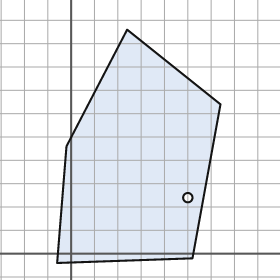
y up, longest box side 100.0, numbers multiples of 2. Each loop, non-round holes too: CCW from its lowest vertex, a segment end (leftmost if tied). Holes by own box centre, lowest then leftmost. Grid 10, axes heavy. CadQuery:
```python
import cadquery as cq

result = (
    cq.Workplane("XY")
    .moveTo(-6.0, -4.0)
    .lineTo(52.0, -2.0)
    .lineTo(64.0, 64.0)
    .lineTo(24.0, 96.0)
    .lineTo(-2.0, 46.0)
    .close()
    .moveTo(50.0, 24.0)
    .circle(2.0)
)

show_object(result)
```